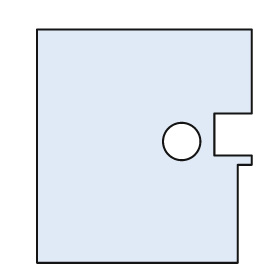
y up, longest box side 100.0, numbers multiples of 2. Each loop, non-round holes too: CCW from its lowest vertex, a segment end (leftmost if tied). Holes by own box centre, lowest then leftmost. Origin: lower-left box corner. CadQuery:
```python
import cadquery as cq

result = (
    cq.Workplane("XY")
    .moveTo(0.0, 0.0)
    .lineTo(86.0, 0.0)
    .lineTo(86.0, 42.0)
    .lineTo(92.0, 42.0)
    .lineTo(92.0, 46.0)
    .lineTo(76.0, 46.0)
    .lineTo(76.0, 64.0)
    .lineTo(92.0, 64.0)
    .lineTo(92.0, 100.0)
    .lineTo(0.0, 100.0)
    .close()
    .moveTo(62.0, 52.0)
    .circle(8.0)
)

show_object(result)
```